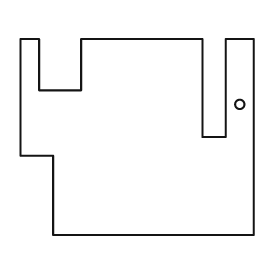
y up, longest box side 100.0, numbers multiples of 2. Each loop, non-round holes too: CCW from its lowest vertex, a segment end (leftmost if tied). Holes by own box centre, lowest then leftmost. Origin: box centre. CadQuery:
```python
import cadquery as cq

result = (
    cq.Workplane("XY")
    .moveTo(-36.0, -42.0)
    .lineTo(50.0, -42.0)
    .lineTo(50.0, 42.0)
    .lineTo(38.0, 42.0)
    .lineTo(38.0, 0.0)
    .lineTo(28.0, 0.0)
    .lineTo(28.0, 42.0)
    .lineTo(-24.0, 42.0)
    .lineTo(-24.0, 20.0)
    .lineTo(-42.0, 20.0)
    .lineTo(-42.0, 42.0)
    .lineTo(-50.0, 42.0)
    .lineTo(-50.0, -8.0)
    .lineTo(-36.0, -8.0)
    .close()
    .moveTo(44.0, 14.0)
    .circle(2.0)
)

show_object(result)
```